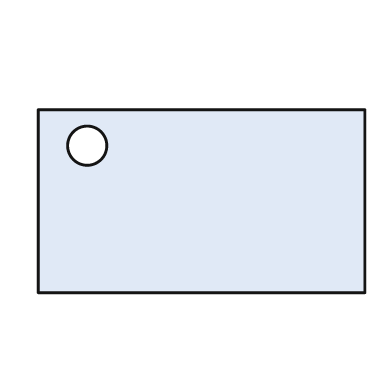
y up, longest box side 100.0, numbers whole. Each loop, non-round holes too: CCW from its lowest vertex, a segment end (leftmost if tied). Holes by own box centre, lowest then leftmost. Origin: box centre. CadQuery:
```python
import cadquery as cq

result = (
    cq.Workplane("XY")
    .moveTo(-50.0, -28.0)
    .lineTo(50.0, -28.0)
    .lineTo(50.0, 28.0)
    .lineTo(-50.0, 28.0)
    .close()
    .moveTo(-35.0, 17.0)
    .circle(6.0)
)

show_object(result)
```